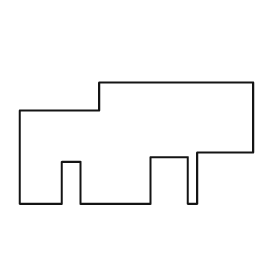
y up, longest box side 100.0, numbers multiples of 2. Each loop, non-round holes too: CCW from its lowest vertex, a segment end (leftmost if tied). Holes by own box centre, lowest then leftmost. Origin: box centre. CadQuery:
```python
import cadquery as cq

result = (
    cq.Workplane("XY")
    .moveTo(-50.0, -26.0)
    .lineTo(-32.0, -26.0)
    .lineTo(-32.0, -8.0)
    .lineTo(-24.0, -8.0)
    .lineTo(-24.0, -26.0)
    .lineTo(6.0, -26.0)
    .lineTo(6.0, -6.0)
    .lineTo(22.0, -6.0)
    .lineTo(22.0, -26.0)
    .lineTo(26.0, -26.0)
    .lineTo(26.0, -4.0)
    .lineTo(50.0, -4.0)
    .lineTo(50.0, 26.0)
    .lineTo(-16.0, 26.0)
    .lineTo(-16.0, 14.0)
    .lineTo(-50.0, 14.0)
    .close()
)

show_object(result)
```